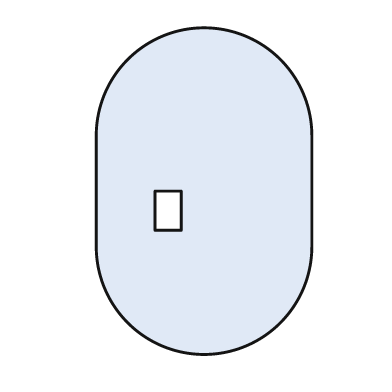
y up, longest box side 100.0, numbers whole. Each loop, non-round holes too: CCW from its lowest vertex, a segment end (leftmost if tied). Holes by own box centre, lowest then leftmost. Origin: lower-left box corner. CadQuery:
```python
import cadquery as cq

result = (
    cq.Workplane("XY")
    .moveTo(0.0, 33.0)
    .threePointArc((33.0, 0.0), (66.0, 33.0))
    .lineTo(66.0, 67.0)
    .threePointArc((33.0, 100.0), (0.0, 67.0))
    .close()
    .moveTo(18.0, 38.0)
    .lineTo(26.0, 38.0)
    .lineTo(26.0, 50.0)
    .lineTo(18.0, 50.0)
    .close()
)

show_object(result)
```